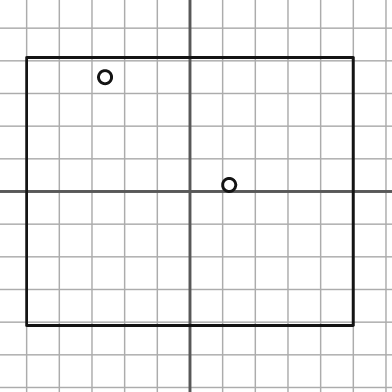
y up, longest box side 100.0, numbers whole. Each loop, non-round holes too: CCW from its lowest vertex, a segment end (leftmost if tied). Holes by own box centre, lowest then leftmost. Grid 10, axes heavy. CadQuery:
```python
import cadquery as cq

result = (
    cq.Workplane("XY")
    .moveTo(-50.0, -41.0)
    .lineTo(50.0, -41.0)
    .lineTo(50.0, 41.0)
    .lineTo(-50.0, 41.0)
    .close()
    .moveTo(12.0, 2.0)
    .circle(2.0)
    .moveTo(-26.0, 35.0)
    .circle(2.0)
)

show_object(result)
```